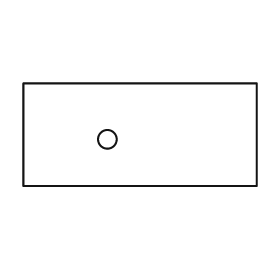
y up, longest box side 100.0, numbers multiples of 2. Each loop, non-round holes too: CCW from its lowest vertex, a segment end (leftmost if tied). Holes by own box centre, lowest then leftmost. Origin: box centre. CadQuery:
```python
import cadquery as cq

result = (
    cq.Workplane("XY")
    .moveTo(-50.0, -22.0)
    .lineTo(50.0, -22.0)
    .lineTo(50.0, 22.0)
    .lineTo(-50.0, 22.0)
    .close()
    .moveTo(-14.0, -2.0)
    .circle(4.0)
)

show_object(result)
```